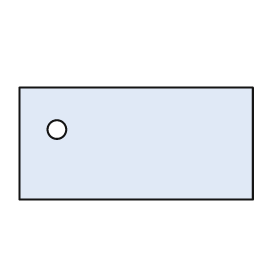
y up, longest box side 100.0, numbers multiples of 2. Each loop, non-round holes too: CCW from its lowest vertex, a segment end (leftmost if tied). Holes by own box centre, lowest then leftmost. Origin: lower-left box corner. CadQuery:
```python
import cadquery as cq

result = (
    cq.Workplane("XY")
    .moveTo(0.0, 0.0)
    .lineTo(100.0, 0.0)
    .lineTo(100.0, 48.0)
    .lineTo(0.0, 48.0)
    .close()
    .moveTo(16.0, 30.0)
    .circle(4.0)
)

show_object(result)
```